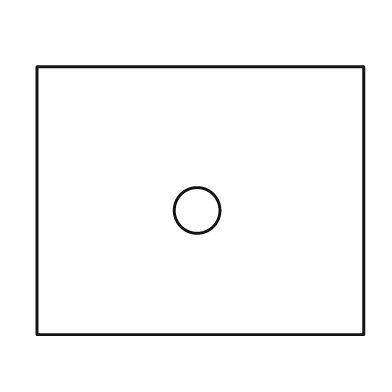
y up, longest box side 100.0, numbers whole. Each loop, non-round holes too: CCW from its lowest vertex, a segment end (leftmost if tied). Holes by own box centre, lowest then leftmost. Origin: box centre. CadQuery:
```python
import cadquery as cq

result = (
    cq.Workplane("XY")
    .moveTo(-50.0, -41.0)
    .lineTo(50.0, -41.0)
    .lineTo(50.0, 41.0)
    .lineTo(-50.0, 41.0)
    .close()
    .moveTo(-1.0, -3.0)
    .circle(7.0)
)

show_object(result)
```